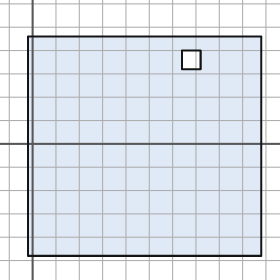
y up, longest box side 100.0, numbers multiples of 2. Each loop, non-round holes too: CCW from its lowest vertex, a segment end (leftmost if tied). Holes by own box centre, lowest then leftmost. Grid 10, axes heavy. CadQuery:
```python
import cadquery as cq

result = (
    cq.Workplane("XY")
    .moveTo(-2.0, -48.0)
    .lineTo(98.0, -48.0)
    .lineTo(98.0, 46.0)
    .lineTo(-2.0, 46.0)
    .close()
    .moveTo(64.0, 32.0)
    .lineTo(72.0, 32.0)
    .lineTo(72.0, 40.0)
    .lineTo(64.0, 40.0)
    .close()
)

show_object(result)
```